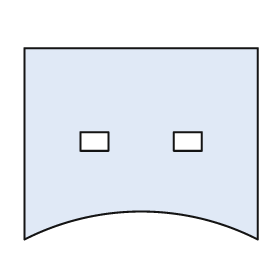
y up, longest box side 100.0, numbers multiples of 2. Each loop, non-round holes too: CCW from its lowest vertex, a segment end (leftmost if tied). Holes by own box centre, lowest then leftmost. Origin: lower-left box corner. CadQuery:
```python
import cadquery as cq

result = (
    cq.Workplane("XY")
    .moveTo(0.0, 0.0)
    .threePointArc((50.0, 12.0), (100.0, 0.0))
    .lineTo(100.0, 82.0)
    .lineTo(0.0, 82.0)
    .close()
    .moveTo(24.0, 38.0)
    .lineTo(36.0, 38.0)
    .lineTo(36.0, 46.0)
    .lineTo(24.0, 46.0)
    .close()
    .moveTo(64.0, 38.0)
    .lineTo(76.0, 38.0)
    .lineTo(76.0, 46.0)
    .lineTo(64.0, 46.0)
    .close()
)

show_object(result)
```